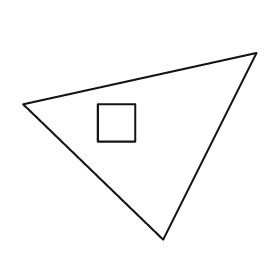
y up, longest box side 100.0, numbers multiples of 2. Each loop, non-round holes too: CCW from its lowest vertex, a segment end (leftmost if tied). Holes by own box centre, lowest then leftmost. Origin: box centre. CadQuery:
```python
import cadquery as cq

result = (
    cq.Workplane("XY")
    .moveTo(10.0, -40.0)
    .lineTo(50.0, 40.0)
    .lineTo(-50.0, 18.0)
    .close()
    .moveTo(-18.0, 2.0)
    .lineTo(-2.0, 2.0)
    .lineTo(-2.0, 18.0)
    .lineTo(-18.0, 18.0)
    .close()
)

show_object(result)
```